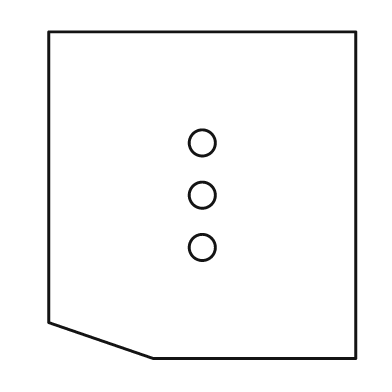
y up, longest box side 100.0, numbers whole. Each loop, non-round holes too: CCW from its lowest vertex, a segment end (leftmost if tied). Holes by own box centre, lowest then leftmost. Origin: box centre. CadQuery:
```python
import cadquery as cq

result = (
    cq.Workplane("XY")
    .moveTo(-15.0, -50.0)
    .lineTo(47.0, -50.0)
    .lineTo(47.0, 50.0)
    .lineTo(-47.0, 50.0)
    .lineTo(-47.0, -39.0)
    .close()
    .moveTo(0.0, -16.0)
    .circle(4.0)
    .moveTo(0.0, 0.0)
    .circle(4.0)
    .moveTo(0.0, 16.0)
    .circle(4.0)
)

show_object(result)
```